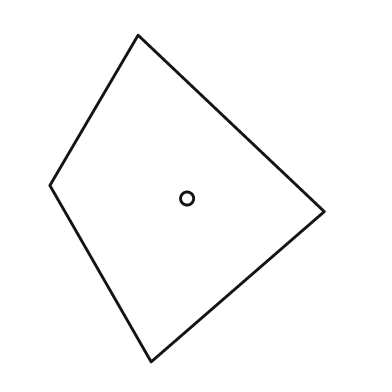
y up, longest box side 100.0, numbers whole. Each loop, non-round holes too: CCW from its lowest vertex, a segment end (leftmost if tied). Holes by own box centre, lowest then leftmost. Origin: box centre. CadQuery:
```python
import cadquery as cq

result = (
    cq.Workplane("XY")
    .moveTo(-11.0, -50.0)
    .lineTo(42.0, -4.0)
    .lineTo(-15.0, 50.0)
    .lineTo(-42.0, 4.0)
    .close()
    .moveTo(0.0, 0.0)
    .circle(2.0)
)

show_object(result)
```